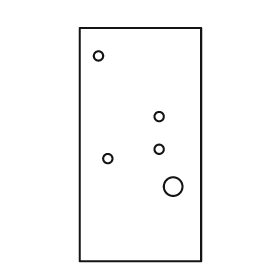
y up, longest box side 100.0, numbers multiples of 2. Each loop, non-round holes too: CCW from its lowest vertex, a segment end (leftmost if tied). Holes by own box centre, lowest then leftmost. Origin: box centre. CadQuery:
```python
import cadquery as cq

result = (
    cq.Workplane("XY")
    .moveTo(-26.0, -50.0)
    .lineTo(26.0, -50.0)
    .lineTo(26.0, 50.0)
    .lineTo(-26.0, 50.0)
    .close()
    .moveTo(14.0, -18.0)
    .circle(4.0)
    .moveTo(-14.0, -6.0)
    .circle(2.0)
    .moveTo(8.0, -2.0)
    .circle(2.0)
    .moveTo(8.0, 12.0)
    .circle(2.0)
    .moveTo(-18.0, 38.0)
    .circle(2.0)
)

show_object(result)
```